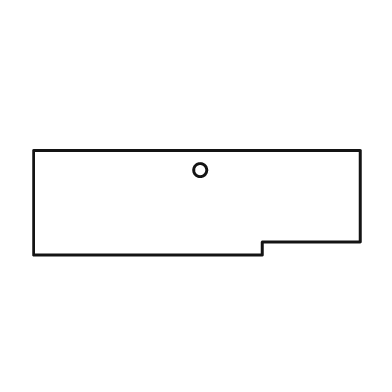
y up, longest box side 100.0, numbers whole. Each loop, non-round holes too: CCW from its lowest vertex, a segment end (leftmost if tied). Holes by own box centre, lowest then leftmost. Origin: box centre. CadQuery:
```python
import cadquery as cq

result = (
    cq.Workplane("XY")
    .moveTo(-50.0, -16.0)
    .lineTo(20.0, -16.0)
    .lineTo(20.0, -12.0)
    .lineTo(50.0, -12.0)
    .lineTo(50.0, 16.0)
    .lineTo(-50.0, 16.0)
    .close()
    .moveTo(1.0, 10.0)
    .circle(2.0)
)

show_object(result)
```